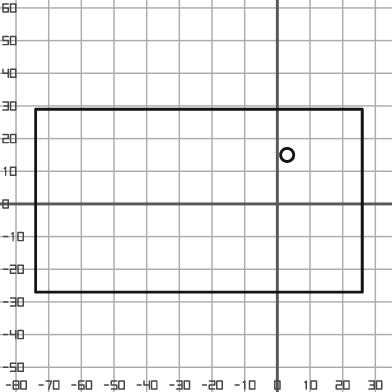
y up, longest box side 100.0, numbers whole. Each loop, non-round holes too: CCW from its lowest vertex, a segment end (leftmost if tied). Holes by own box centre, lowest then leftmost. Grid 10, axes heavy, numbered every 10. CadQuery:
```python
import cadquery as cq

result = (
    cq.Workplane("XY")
    .moveTo(-74.0, -27.0)
    .lineTo(26.0, -27.0)
    .lineTo(26.0, 29.0)
    .lineTo(-74.0, 29.0)
    .close()
    .moveTo(3.0, 15.0)
    .circle(2.0)
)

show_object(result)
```